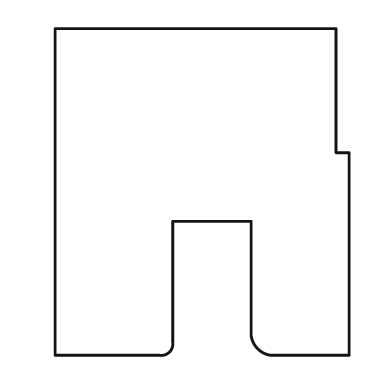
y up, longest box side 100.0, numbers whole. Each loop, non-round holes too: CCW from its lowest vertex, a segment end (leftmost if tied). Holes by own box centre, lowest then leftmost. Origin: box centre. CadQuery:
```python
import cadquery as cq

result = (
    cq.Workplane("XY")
    .moveTo(-45.0, -50.0)
    .lineTo(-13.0, -50.0)
    .threePointArc((-10.0, -49.0), (-9.0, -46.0))
    .lineTo(-9.0, -9.0)
    .lineTo(15.0, -9.0)
    .lineTo(15.0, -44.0)
    .threePointArc((17.0, -48.0), (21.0, -50.0))
    .lineTo(45.0, -50.0)
    .lineTo(45.0, 12.0)
    .lineTo(41.0, 12.0)
    .lineTo(41.0, 50.0)
    .lineTo(-45.0, 50.0)
    .close()
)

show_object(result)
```